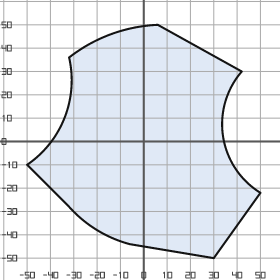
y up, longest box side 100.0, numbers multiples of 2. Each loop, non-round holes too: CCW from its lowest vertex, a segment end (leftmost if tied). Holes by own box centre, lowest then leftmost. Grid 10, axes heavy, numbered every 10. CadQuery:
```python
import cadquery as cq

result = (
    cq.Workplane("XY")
    .moveTo(30.0, -50.0)
    .lineTo(50.0, -22.0)
    .threePointArc((34.0, 2.0), (42.0, 30.0))
    .lineTo(6.0, 50.0)
    .threePointArc((-14.0, 46.0), (-32.0, 36.0))
    .threePointArc((-34.0, 10.0), (-50.0, -10.0))
    .lineTo(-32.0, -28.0)
    .threePointArc((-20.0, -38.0), (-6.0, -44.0))
    .close()
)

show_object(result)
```